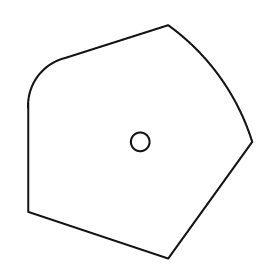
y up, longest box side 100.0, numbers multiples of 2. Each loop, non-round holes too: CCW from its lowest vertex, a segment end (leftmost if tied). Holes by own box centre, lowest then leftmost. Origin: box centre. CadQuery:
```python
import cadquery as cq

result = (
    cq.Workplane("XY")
    .moveTo(12.0, -50.0)
    .lineTo(48.0, 0.0)
    .threePointArc((34.0, 28.0), (12.0, 50.0))
    .lineTo(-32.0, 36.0)
    .threePointArc((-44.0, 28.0), (-48.0, 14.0))
    .lineTo(-48.0, -30.0)
    .close()
    .moveTo(0.0, 0.0)
    .circle(4.0)
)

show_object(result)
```